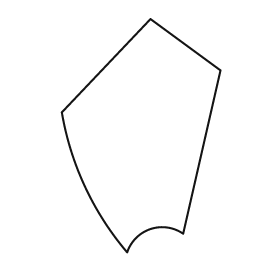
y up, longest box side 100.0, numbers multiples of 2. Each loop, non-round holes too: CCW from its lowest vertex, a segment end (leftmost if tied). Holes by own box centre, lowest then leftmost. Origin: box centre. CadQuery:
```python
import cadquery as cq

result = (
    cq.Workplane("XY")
    .moveTo(-6.0, -50.0)
    .threePointArc((4.0, -40.0), (18.0, -42.0))
    .lineTo(34.0, 28.0)
    .lineTo(4.0, 50.0)
    .lineTo(-34.0, 10.0)
    .threePointArc((-24.0, -22.0), (-6.0, -50.0))
    .close()
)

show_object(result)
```